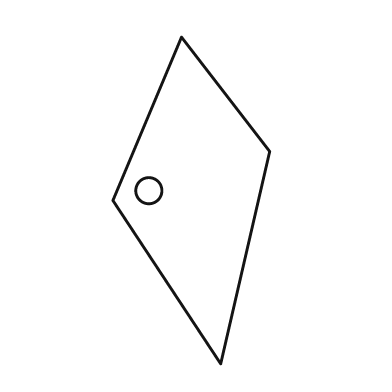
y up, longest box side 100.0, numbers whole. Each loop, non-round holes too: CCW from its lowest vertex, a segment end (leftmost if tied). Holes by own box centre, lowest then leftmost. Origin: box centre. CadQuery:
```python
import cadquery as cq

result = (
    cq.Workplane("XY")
    .moveTo(9.0, -50.0)
    .lineTo(24.0, 15.0)
    .lineTo(-3.0, 50.0)
    .lineTo(-24.0, 0.0)
    .close()
    .moveTo(-13.0, 3.0)
    .circle(4.0)
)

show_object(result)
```